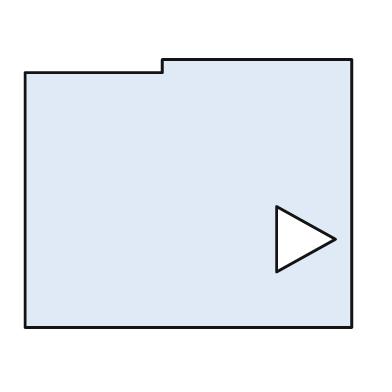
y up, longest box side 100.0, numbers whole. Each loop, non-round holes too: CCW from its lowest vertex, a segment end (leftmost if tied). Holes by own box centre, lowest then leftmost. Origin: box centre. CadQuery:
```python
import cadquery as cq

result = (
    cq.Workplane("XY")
    .moveTo(-50.0, -41.0)
    .lineTo(50.0, -41.0)
    .lineTo(50.0, 41.0)
    .lineTo(-8.0, 41.0)
    .lineTo(-8.0, 37.0)
    .lineTo(-50.0, 37.0)
    .close()
    .moveTo(27.0, -24.0)
    .lineTo(45.0, -14.0)
    .lineTo(27.0, -4.0)
    .close()
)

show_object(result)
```